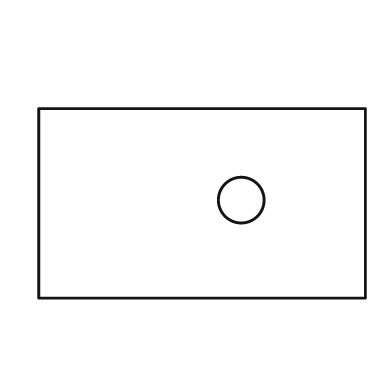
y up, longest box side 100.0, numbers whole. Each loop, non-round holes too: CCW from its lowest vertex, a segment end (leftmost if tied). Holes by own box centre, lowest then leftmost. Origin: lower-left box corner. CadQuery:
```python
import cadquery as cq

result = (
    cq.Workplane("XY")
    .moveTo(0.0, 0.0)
    .lineTo(100.0, 0.0)
    .lineTo(100.0, 58.0)
    .lineTo(0.0, 58.0)
    .close()
    .moveTo(62.0, 30.0)
    .circle(7.0)
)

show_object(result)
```